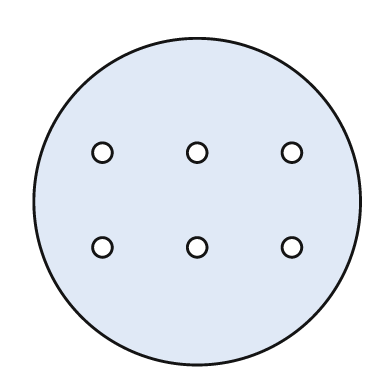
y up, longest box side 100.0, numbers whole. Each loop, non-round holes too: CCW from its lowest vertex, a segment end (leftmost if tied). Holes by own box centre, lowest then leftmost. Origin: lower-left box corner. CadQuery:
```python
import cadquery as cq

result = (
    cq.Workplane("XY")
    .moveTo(50.0, 50.0)
    .circle(50.0)
    .moveTo(21.0, 36.0)
    .circle(3.0)
    .moveTo(50.0, 36.0)
    .circle(3.0)
    .moveTo(79.0, 36.0)
    .circle(3.0)
    .moveTo(21.0, 65.0)
    .circle(3.0)
    .moveTo(50.0, 65.0)
    .circle(3.0)
    .moveTo(79.0, 65.0)
    .circle(3.0)
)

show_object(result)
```